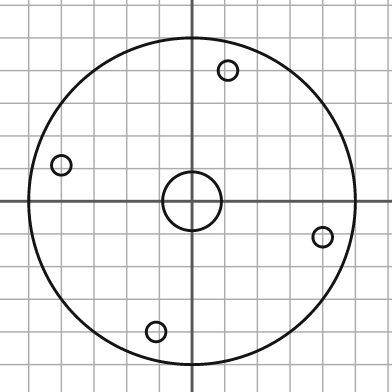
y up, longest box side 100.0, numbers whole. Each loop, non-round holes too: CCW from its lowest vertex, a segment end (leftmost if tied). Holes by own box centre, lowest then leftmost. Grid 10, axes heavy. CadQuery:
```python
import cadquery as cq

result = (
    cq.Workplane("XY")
    .moveTo(0.0, 0.0)
    .circle(50.0)
    .moveTo(-11.0, -40.0)
    .circle(3.0)
    .moveTo(40.0, -11.0)
    .circle(3.0)
    .moveTo(0.0, 0.0)
    .circle(9.0)
    .moveTo(-40.0, 11.0)
    .circle(3.0)
    .moveTo(11.0, 40.0)
    .circle(3.0)
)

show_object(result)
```